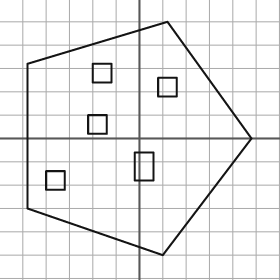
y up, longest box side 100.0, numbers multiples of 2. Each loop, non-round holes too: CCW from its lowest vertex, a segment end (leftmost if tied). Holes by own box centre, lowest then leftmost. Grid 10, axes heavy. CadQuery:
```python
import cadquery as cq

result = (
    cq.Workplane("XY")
    .moveTo(10.0, -50.0)
    .lineTo(48.0, 0.0)
    .lineTo(12.0, 50.0)
    .lineTo(-48.0, 32.0)
    .lineTo(-48.0, -30.0)
    .close()
    .moveTo(-40.0, -22.0)
    .lineTo(-32.0, -22.0)
    .lineTo(-32.0, -14.0)
    .lineTo(-40.0, -14.0)
    .close()
    .moveTo(-2.0, -18.0)
    .lineTo(6.0, -18.0)
    .lineTo(6.0, -6.0)
    .lineTo(-2.0, -6.0)
    .close()
    .moveTo(-22.0, 2.0)
    .lineTo(-14.0, 2.0)
    .lineTo(-14.0, 10.0)
    .lineTo(-22.0, 10.0)
    .close()
    .moveTo(8.0, 18.0)
    .lineTo(16.0, 18.0)
    .lineTo(16.0, 26.0)
    .lineTo(8.0, 26.0)
    .close()
    .moveTo(-20.0, 24.0)
    .lineTo(-12.0, 24.0)
    .lineTo(-12.0, 32.0)
    .lineTo(-20.0, 32.0)
    .close()
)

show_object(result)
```